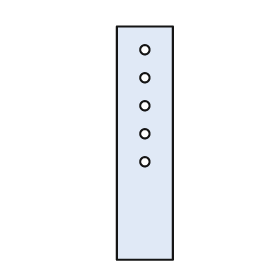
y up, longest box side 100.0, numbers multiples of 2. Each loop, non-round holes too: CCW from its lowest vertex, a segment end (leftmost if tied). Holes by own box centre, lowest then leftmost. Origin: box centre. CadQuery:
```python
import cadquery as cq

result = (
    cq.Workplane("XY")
    .moveTo(-12.0, -50.0)
    .lineTo(12.0, -50.0)
    .lineTo(12.0, 50.0)
    .lineTo(-12.0, 50.0)
    .close()
    .moveTo(0.0, -8.0)
    .circle(2.0)
    .moveTo(0.0, 4.0)
    .circle(2.0)
    .moveTo(0.0, 16.0)
    .circle(2.0)
    .moveTo(0.0, 28.0)
    .circle(2.0)
    .moveTo(0.0, 40.0)
    .circle(2.0)
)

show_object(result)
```